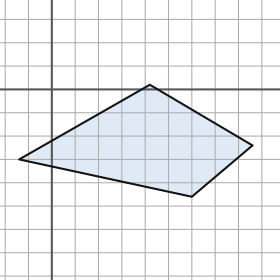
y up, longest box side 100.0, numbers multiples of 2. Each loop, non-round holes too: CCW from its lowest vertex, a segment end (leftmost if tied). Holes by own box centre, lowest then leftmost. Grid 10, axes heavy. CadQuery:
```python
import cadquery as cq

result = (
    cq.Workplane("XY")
    .moveTo(60.0, -46.0)
    .lineTo(86.0, -24.0)
    .lineTo(42.0, 2.0)
    .lineTo(-14.0, -30.0)
    .close()
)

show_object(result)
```